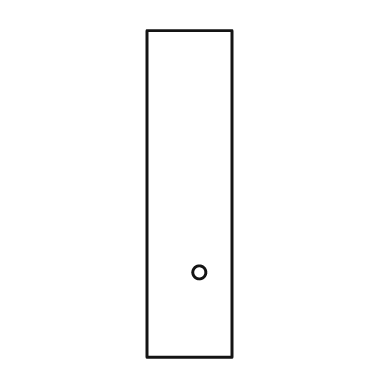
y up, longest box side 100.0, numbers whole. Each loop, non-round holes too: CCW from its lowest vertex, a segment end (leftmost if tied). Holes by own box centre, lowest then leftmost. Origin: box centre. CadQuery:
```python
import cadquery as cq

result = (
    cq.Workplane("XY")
    .moveTo(-13.0, -50.0)
    .lineTo(13.0, -50.0)
    .lineTo(13.0, 50.0)
    .lineTo(-13.0, 50.0)
    .close()
    .moveTo(3.0, -24.0)
    .circle(2.0)
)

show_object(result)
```